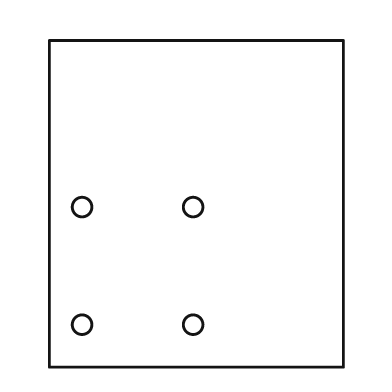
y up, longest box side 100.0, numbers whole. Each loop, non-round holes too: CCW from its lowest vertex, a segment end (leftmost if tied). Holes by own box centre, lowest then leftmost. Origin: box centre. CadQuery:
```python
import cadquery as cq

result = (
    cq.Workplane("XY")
    .moveTo(-45.0, -50.0)
    .lineTo(45.0, -50.0)
    .lineTo(45.0, 50.0)
    .lineTo(-45.0, 50.0)
    .close()
    .moveTo(-35.0, -37.0)
    .circle(3.0)
    .moveTo(-1.0, -37.0)
    .circle(3.0)
    .moveTo(-35.0, -1.0)
    .circle(3.0)
    .moveTo(-1.0, -1.0)
    .circle(3.0)
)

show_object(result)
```